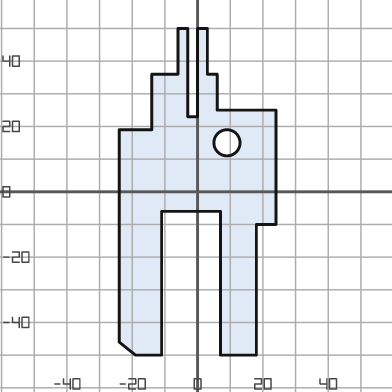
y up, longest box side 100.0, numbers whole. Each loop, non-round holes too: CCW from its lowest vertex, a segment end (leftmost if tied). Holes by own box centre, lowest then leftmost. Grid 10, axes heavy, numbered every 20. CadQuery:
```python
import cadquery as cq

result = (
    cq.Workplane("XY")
    .moveTo(-19.0, -50.0)
    .lineTo(-11.0, -50.0)
    .lineTo(-11.0, -6.0)
    .lineTo(7.0, -6.0)
    .lineTo(7.0, -50.0)
    .lineTo(18.0, -50.0)
    .lineTo(18.0, -10.0)
    .lineTo(24.0, -10.0)
    .lineTo(24.0, 25.0)
    .lineTo(6.0, 25.0)
    .lineTo(6.0, 36.0)
    .lineTo(3.0, 36.0)
    .lineTo(3.0, 50.0)
    .lineTo(0.0, 50.0)
    .lineTo(0.0, 23.0)
    .lineTo(-3.0, 23.0)
    .lineTo(-3.0, 50.0)
    .lineTo(-6.0, 50.0)
    .lineTo(-6.0, 36.0)
    .lineTo(-14.0, 36.0)
    .lineTo(-14.0, 19.0)
    .lineTo(-24.0, 19.0)
    .lineTo(-24.0, -46.0)
    .close()
    .moveTo(9.0, 15.0)
    .circle(4.0)
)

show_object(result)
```